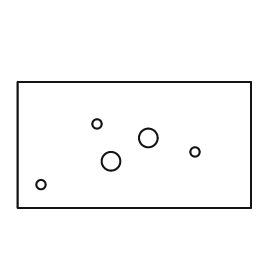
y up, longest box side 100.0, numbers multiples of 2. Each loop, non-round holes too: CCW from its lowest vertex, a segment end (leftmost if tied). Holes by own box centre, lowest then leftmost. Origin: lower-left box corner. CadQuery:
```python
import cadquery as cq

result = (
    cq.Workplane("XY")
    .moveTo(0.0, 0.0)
    .lineTo(100.0, 0.0)
    .lineTo(100.0, 54.0)
    .lineTo(0.0, 54.0)
    .close()
    .moveTo(10.0, 10.0)
    .circle(2.0)
    .moveTo(40.0, 20.0)
    .circle(4.0)
    .moveTo(76.0, 24.0)
    .circle(2.0)
    .moveTo(56.0, 30.0)
    .circle(4.0)
    .moveTo(34.0, 36.0)
    .circle(2.0)
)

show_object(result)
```